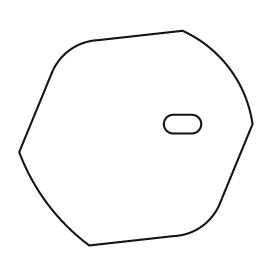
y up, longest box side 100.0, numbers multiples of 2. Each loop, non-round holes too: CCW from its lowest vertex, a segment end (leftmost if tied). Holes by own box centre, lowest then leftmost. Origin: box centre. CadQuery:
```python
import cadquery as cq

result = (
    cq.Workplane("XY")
    .moveTo(-20.0, -46.0)
    .lineTo(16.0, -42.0)
    .threePointArc((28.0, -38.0), (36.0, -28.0))
    .lineTo(50.0, 6.0)
    .threePointArc((40.0, 30.0), (20.0, 46.0))
    .lineTo(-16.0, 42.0)
    .threePointArc((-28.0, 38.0), (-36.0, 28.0))
    .lineTo(-50.0, -6.0)
    .threePointArc((-38.0, -28.0), (-20.0, -46.0))
    .close()
    .moveTo(16.0, 2.0)
    .lineTo(24.0, 2.0)
    .threePointArc((28.0, 6.0), (24.0, 10.0))
    .lineTo(16.0, 10.0)
    .threePointArc((12.0, 6.0), (16.0, 2.0))
    .close()
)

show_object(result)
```